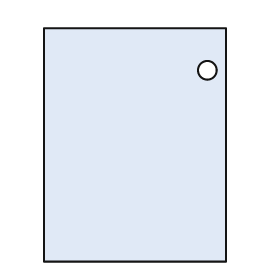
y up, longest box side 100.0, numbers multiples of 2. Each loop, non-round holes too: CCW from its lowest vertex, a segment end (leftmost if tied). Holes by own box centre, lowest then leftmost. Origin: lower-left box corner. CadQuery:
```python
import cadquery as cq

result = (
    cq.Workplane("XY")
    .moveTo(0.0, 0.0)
    .lineTo(78.0, 0.0)
    .lineTo(78.0, 100.0)
    .lineTo(0.0, 100.0)
    .close()
    .moveTo(70.0, 82.0)
    .circle(4.0)
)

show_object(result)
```